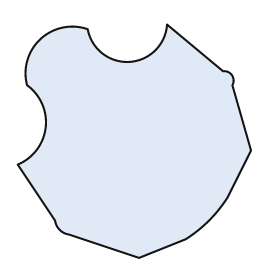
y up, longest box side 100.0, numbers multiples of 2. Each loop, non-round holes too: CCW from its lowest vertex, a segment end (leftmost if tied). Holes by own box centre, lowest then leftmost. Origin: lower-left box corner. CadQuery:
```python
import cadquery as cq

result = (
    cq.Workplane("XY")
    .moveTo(52.0, 0.0)
    .lineTo(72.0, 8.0)
    .threePointArc((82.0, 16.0), (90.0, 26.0))
    .lineTo(100.0, 46.0)
    .lineTo(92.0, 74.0)
    .threePointArc((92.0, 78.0), (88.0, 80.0))
    .lineTo(64.0, 100.0)
    .threePointArc((48.0, 84.0), (30.0, 98.0))
    .threePointArc((10.0, 94.0), (4.0, 74.0))
    .threePointArc((12.0, 56.0), (0.0, 40.0))
    .lineTo(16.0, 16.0)
    .threePointArc((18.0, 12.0), (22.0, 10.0))
    .close()
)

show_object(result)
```